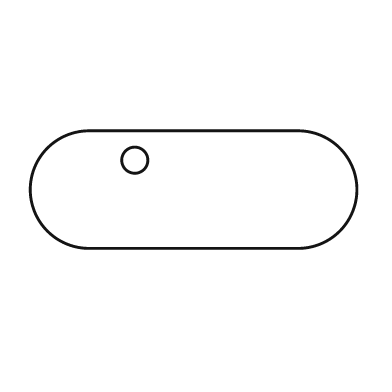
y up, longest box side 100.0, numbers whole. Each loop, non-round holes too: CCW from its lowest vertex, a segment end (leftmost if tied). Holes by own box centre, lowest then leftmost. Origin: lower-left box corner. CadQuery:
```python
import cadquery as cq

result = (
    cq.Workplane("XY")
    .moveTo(18.0, 0.0)
    .lineTo(82.0, 0.0)
    .threePointArc((100.0, 18.0), (82.0, 36.0))
    .lineTo(18.0, 36.0)
    .threePointArc((0.0, 18.0), (18.0, 0.0))
    .close()
    .moveTo(32.0, 27.0)
    .circle(4.0)
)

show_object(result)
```